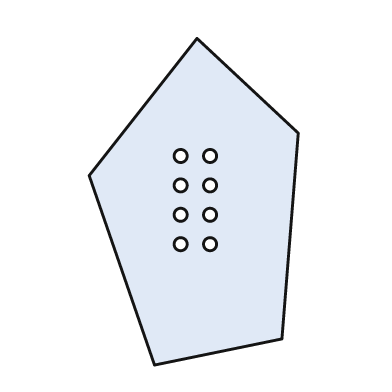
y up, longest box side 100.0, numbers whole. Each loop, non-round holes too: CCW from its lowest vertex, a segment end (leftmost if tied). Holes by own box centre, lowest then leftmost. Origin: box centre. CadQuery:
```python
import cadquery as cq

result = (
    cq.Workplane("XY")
    .moveTo(-12.0, -50.0)
    .lineTo(27.0, -42.0)
    .lineTo(32.0, 21.0)
    .lineTo(1.0, 50.0)
    .lineTo(-32.0, 8.0)
    .close()
    .moveTo(-4.0, -13.0)
    .circle(2.0)
    .moveTo(5.0, -13.0)
    .circle(2.0)
    .moveTo(-4.0, -4.0)
    .circle(2.0)
    .moveTo(5.0, -4.0)
    .circle(2.0)
    .moveTo(-4.0, 5.0)
    .circle(2.0)
    .moveTo(5.0, 5.0)
    .circle(2.0)
    .moveTo(-4.0, 14.0)
    .circle(2.0)
    .moveTo(5.0, 14.0)
    .circle(2.0)
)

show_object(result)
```